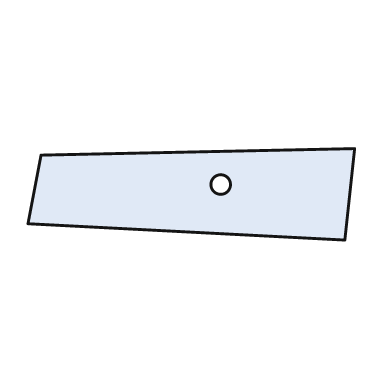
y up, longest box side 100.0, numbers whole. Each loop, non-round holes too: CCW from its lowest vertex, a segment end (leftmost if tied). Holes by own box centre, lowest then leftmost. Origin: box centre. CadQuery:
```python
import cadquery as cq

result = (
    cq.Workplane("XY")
    .moveTo(47.0, -14.0)
    .lineTo(50.0, 14.0)
    .lineTo(-46.0, 12.0)
    .lineTo(-50.0, -9.0)
    .close()
    .moveTo(9.0, 3.0)
    .circle(3.0)
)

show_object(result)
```